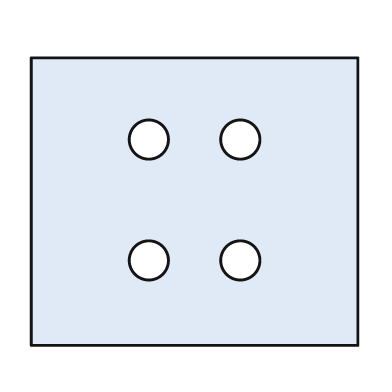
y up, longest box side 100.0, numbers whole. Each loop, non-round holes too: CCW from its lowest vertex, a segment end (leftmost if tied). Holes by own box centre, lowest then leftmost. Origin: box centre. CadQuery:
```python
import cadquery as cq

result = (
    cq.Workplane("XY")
    .moveTo(-50.0, -44.0)
    .lineTo(50.0, -44.0)
    .lineTo(50.0, 44.0)
    .lineTo(-50.0, 44.0)
    .close()
    .moveTo(-14.0, -18.0)
    .circle(6.0)
    .moveTo(14.0, -18.0)
    .circle(6.0)
    .moveTo(-14.0, 19.0)
    .circle(6.0)
    .moveTo(14.0, 19.0)
    .circle(6.0)
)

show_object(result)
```